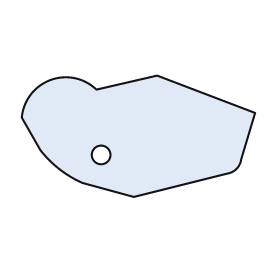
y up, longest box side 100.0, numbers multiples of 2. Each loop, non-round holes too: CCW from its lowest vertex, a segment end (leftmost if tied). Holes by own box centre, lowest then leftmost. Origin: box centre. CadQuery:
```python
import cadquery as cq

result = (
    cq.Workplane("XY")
    .moveTo(-2.0, -26.0)
    .lineTo(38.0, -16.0)
    .threePointArc((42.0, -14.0), (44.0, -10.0))
    .lineTo(50.0, 10.0)
    .lineTo(8.0, 26.0)
    .lineTo(-18.0, 20.0)
    .threePointArc((-38.0, 24.0), (-50.0, 8.0))
    .lineTo(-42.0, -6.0)
    .threePointArc((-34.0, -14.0), (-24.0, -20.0))
    .close()
    .moveTo(-16.0, -8.0)
    .circle(4.0)
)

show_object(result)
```